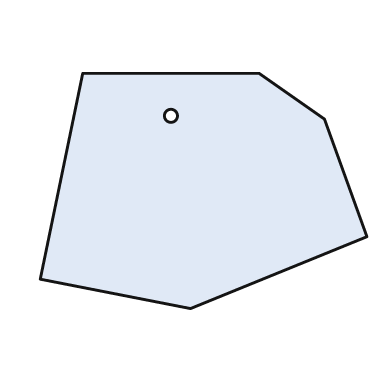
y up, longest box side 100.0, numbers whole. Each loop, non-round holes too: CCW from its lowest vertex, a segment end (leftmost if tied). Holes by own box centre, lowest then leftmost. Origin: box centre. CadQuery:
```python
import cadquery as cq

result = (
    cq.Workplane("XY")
    .moveTo(-4.0, -36.0)
    .lineTo(50.0, -14.0)
    .lineTo(37.0, 22.0)
    .lineTo(17.0, 36.0)
    .lineTo(-37.0, 36.0)
    .lineTo(-50.0, -27.0)
    .close()
    .moveTo(-10.0, 23.0)
    .circle(2.0)
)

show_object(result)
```